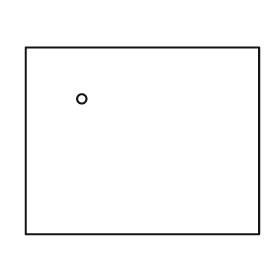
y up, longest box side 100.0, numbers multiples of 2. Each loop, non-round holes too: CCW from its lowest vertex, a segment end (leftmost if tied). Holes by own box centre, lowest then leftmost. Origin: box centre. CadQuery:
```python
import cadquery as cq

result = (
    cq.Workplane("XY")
    .moveTo(-50.0, -40.0)
    .lineTo(50.0, -40.0)
    .lineTo(50.0, 40.0)
    .lineTo(-50.0, 40.0)
    .close()
    .moveTo(-26.0, 18.0)
    .circle(2.0)
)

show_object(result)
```